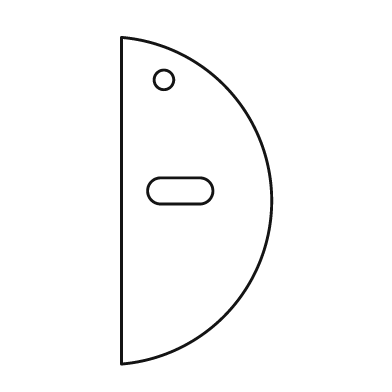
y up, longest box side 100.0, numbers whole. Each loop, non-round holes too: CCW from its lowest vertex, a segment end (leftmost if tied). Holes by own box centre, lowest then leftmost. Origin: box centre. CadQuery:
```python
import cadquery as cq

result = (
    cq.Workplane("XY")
    .moveTo(-23.0, -50.0)
    .threePointArc((23.0, 0.0), (-23.0, 50.0))
    .close()
    .moveTo(-11.0, -1.0)
    .lineTo(1.0, -1.0)
    .threePointArc((5.0, 3.0), (1.0, 7.0))
    .lineTo(-11.0, 7.0)
    .threePointArc((-15.0, 3.0), (-11.0, -1.0))
    .close()
    .moveTo(-10.0, 37.0)
    .circle(3.0)
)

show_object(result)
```